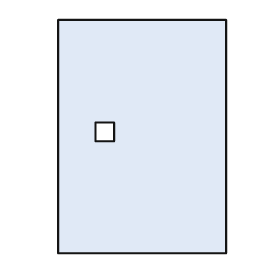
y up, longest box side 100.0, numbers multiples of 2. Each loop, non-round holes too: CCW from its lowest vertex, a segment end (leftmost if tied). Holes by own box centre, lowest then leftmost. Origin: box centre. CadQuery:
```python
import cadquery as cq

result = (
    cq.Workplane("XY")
    .moveTo(-36.0, -50.0)
    .lineTo(36.0, -50.0)
    .lineTo(36.0, 50.0)
    .lineTo(-36.0, 50.0)
    .close()
    .moveTo(-20.0, -2.0)
    .lineTo(-12.0, -2.0)
    .lineTo(-12.0, 6.0)
    .lineTo(-20.0, 6.0)
    .close()
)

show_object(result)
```